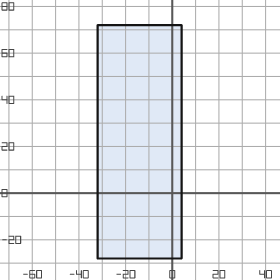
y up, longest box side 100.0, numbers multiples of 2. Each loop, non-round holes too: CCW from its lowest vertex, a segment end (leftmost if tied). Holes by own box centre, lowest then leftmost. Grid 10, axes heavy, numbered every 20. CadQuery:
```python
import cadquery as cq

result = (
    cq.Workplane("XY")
    .moveTo(-32.0, -28.0)
    .lineTo(4.0, -28.0)
    .lineTo(4.0, 72.0)
    .lineTo(-32.0, 72.0)
    .close()
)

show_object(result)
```